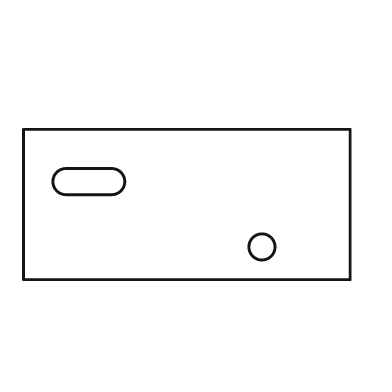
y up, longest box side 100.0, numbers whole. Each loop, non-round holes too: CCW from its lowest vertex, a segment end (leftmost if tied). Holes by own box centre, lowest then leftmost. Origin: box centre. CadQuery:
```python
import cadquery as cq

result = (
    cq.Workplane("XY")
    .moveTo(-50.0, -23.0)
    .lineTo(50.0, -23.0)
    .lineTo(50.0, 23.0)
    .lineTo(-50.0, 23.0)
    .close()
    .moveTo(23.0, -13.0)
    .circle(4.0)
    .moveTo(-37.0, 3.0)
    .lineTo(-23.0, 3.0)
    .threePointArc((-19.0, 7.0), (-23.0, 11.0))
    .lineTo(-37.0, 11.0)
    .threePointArc((-41.0, 7.0), (-37.0, 3.0))
    .close()
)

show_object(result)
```